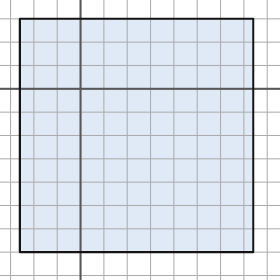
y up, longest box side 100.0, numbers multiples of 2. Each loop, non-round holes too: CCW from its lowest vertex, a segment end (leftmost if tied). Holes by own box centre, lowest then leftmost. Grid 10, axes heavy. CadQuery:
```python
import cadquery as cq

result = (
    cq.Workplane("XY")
    .moveTo(-26.0, -70.0)
    .lineTo(74.0, -70.0)
    .lineTo(74.0, 30.0)
    .lineTo(-26.0, 30.0)
    .close()
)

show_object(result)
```